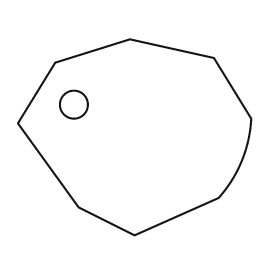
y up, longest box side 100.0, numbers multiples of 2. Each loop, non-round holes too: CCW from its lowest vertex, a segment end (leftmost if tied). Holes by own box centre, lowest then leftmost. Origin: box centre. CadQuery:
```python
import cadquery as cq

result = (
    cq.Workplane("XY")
    .moveTo(0.0, -42.0)
    .lineTo(36.0, -26.0)
    .threePointArc((46.0, -10.0), (50.0, 8.0))
    .lineTo(34.0, 34.0)
    .lineTo(-2.0, 42.0)
    .lineTo(-34.0, 32.0)
    .lineTo(-50.0, 6.0)
    .lineTo(-24.0, -30.0)
    .close()
    .moveTo(-26.0, 14.0)
    .circle(6.0)
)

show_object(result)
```